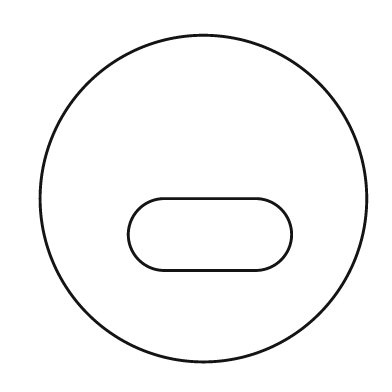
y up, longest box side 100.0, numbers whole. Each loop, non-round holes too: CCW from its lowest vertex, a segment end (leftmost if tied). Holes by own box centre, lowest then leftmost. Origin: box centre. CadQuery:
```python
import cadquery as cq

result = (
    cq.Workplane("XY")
    .moveTo(0.0, 0.0)
    .circle(50.0)
    .moveTo(-12.0, -22.0)
    .lineTo(16.0, -22.0)
    .threePointArc((27.0, -11.0), (16.0, 0.0))
    .lineTo(-12.0, 0.0)
    .threePointArc((-23.0, -11.0), (-12.0, -22.0))
    .close()
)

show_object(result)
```